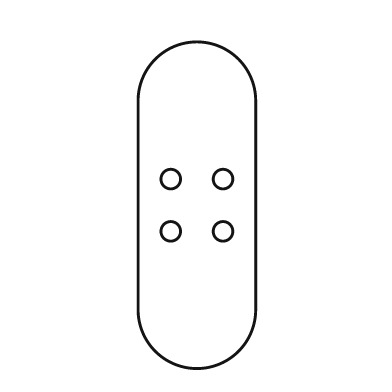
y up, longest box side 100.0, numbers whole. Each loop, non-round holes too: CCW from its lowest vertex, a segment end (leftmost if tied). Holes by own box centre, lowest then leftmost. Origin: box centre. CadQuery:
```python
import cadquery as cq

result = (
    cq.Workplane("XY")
    .moveTo(-18.0, -32.0)
    .threePointArc((0.0, -50.0), (18.0, -32.0))
    .lineTo(18.0, 32.0)
    .threePointArc((0.0, 50.0), (-18.0, 32.0))
    .close()
    .moveTo(-8.0, -8.0)
    .circle(3.0)
    .moveTo(8.0, -8.0)
    .circle(3.0)
    .moveTo(-8.0, 8.0)
    .circle(3.0)
    .moveTo(8.0, 8.0)
    .circle(3.0)
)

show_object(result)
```